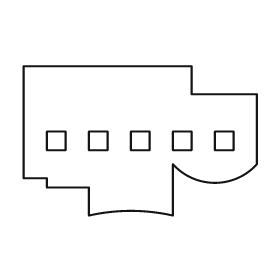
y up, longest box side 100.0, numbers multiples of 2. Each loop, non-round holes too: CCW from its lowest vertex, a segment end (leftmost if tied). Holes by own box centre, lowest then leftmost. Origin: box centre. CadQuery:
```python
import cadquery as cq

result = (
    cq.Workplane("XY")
    .moveTo(-22.0, -32.0)
    .threePointArc((-4.0, -30.0), (14.0, -32.0))
    .lineTo(14.0, -10.0)
    .threePointArc((32.0, -18.0), (50.0, -10.0))
    .lineTo(50.0, 20.0)
    .lineTo(22.0, 20.0)
    .lineTo(22.0, 32.0)
    .lineTo(-50.0, 32.0)
    .lineTo(-50.0, -16.0)
    .lineTo(-40.0, -16.0)
    .lineTo(-40.0, -20.0)
    .lineTo(-22.0, -20.0)
    .close()
    .moveTo(-40.0, -4.0)
    .lineTo(-32.0, -4.0)
    .lineTo(-32.0, 4.0)
    .lineTo(-40.0, 4.0)
    .close()
    .moveTo(-22.0, -4.0)
    .lineTo(-14.0, -4.0)
    .lineTo(-14.0, 4.0)
    .lineTo(-22.0, 4.0)
    .close()
    .moveTo(-4.0, -4.0)
    .lineTo(4.0, -4.0)
    .lineTo(4.0, 4.0)
    .lineTo(-4.0, 4.0)
    .close()
    .moveTo(14.0, -4.0)
    .lineTo(22.0, -4.0)
    .lineTo(22.0, 4.0)
    .lineTo(14.0, 4.0)
    .close()
    .moveTo(32.0, -4.0)
    .lineTo(40.0, -4.0)
    .lineTo(40.0, 4.0)
    .lineTo(32.0, 4.0)
    .close()
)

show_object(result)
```